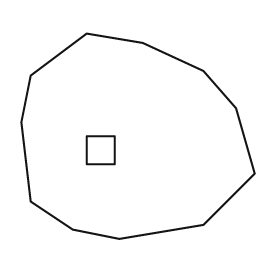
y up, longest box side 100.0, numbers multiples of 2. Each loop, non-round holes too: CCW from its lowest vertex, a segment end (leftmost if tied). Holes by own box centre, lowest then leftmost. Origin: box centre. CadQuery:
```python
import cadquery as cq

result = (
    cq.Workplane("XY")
    .moveTo(-8.0, -44.0)
    .lineTo(28.0, -38.0)
    .lineTo(50.0, -16.0)
    .lineTo(42.0, 12.0)
    .lineTo(28.0, 28.0)
    .lineTo(2.0, 40.0)
    .lineTo(-22.0, 44.0)
    .lineTo(-46.0, 26.0)
    .lineTo(-50.0, 6.0)
    .lineTo(-46.0, -28.0)
    .lineTo(-28.0, -40.0)
    .close()
    .moveTo(-22.0, -12.0)
    .lineTo(-10.0, -12.0)
    .lineTo(-10.0, 0.0)
    .lineTo(-22.0, 0.0)
    .close()
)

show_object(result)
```